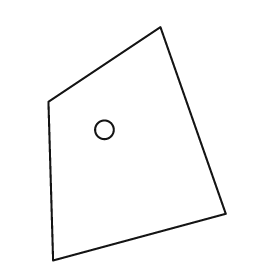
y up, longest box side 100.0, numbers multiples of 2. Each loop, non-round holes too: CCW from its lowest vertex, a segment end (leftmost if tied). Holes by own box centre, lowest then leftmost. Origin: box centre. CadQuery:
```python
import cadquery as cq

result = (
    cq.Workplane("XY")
    .moveTo(-36.0, -50.0)
    .lineTo(38.0, -30.0)
    .lineTo(10.0, 50.0)
    .lineTo(-38.0, 18.0)
    .close()
    .moveTo(-14.0, 6.0)
    .circle(4.0)
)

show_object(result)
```